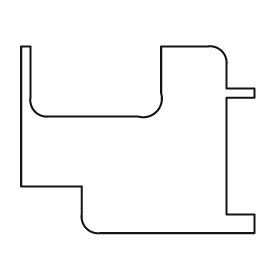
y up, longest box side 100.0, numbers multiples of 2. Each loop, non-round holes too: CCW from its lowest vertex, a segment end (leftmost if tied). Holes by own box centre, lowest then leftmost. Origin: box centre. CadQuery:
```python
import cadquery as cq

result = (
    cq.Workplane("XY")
    .moveTo(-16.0, -40.0)
    .lineTo(50.0, -40.0)
    .lineTo(50.0, -32.0)
    .lineTo(38.0, -32.0)
    .lineTo(38.0, 18.0)
    .lineTo(50.0, 18.0)
    .lineTo(50.0, 22.0)
    .lineTo(38.0, 22.0)
    .lineTo(38.0, 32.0)
    .threePointArc((36.0, 38.0), (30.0, 40.0))
    .lineTo(10.0, 40.0)
    .lineTo(10.0, 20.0)
    .threePointArc((8.0, 12.0), (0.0, 10.0))
    .lineTo(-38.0, 10.0)
    .threePointArc((-44.0, 12.0), (-46.0, 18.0))
    .lineTo(-46.0, 40.0)
    .lineTo(-50.0, 40.0)
    .lineTo(-50.0, -20.0)
    .lineTo(-24.0, -20.0)
    .lineTo(-24.0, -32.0)
    .threePointArc((-22.0, -38.0), (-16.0, -40.0))
    .close()
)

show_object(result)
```